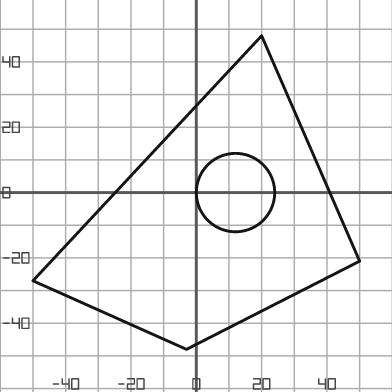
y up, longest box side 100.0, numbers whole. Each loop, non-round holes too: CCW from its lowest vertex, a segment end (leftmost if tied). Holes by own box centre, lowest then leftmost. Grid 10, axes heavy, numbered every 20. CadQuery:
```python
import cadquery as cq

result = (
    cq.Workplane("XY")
    .moveTo(-3.0, -48.0)
    .lineTo(50.0, -21.0)
    .lineTo(20.0, 48.0)
    .lineTo(-50.0, -27.0)
    .close()
    .moveTo(12.0, 0.0)
    .circle(12.0)
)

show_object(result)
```